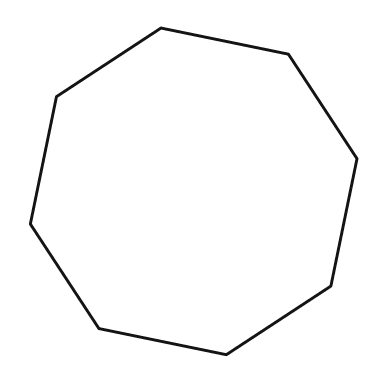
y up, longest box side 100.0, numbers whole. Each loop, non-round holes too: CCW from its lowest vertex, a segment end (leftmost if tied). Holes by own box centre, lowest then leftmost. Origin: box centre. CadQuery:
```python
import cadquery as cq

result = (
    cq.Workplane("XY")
    .moveTo(10.0, -50.0)
    .lineTo(42.0, -29.0)
    .lineTo(50.0, 10.0)
    .lineTo(29.0, 42.0)
    .lineTo(-10.0, 50.0)
    .lineTo(-42.0, 29.0)
    .lineTo(-50.0, -10.0)
    .lineTo(-29.0, -42.0)
    .close()
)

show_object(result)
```